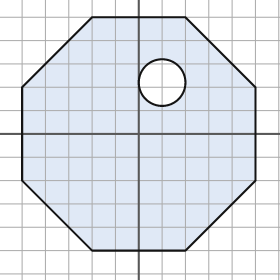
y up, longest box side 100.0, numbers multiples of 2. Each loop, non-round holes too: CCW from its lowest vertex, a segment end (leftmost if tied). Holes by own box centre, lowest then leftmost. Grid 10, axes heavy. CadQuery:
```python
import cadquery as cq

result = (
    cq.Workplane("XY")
    .moveTo(-20.0, -50.0)
    .lineTo(20.0, -50.0)
    .lineTo(50.0, -20.0)
    .lineTo(50.0, 20.0)
    .lineTo(20.0, 50.0)
    .lineTo(-20.0, 50.0)
    .lineTo(-50.0, 20.0)
    .lineTo(-50.0, -20.0)
    .close()
    .moveTo(10.0, 22.0)
    .circle(10.0)
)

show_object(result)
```